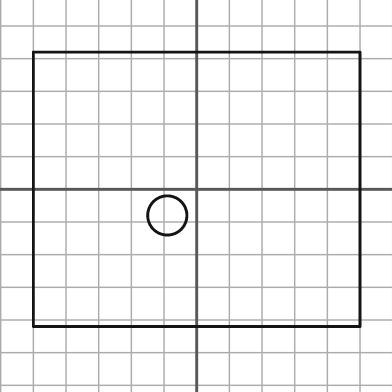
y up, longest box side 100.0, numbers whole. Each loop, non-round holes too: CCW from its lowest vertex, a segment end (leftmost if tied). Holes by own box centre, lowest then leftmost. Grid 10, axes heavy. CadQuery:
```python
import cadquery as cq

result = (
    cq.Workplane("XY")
    .moveTo(-50.0, -42.0)
    .lineTo(50.0, -42.0)
    .lineTo(50.0, 42.0)
    .lineTo(-50.0, 42.0)
    .close()
    .moveTo(-9.0, -8.0)
    .circle(6.0)
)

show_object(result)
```